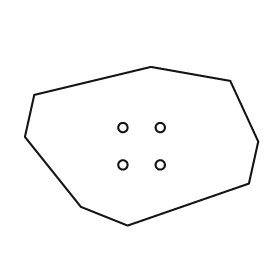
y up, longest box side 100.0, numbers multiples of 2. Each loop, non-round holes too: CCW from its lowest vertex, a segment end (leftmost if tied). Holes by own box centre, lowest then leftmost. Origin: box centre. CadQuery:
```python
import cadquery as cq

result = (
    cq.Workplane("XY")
    .moveTo(-6.0, -34.0)
    .lineTo(46.0, -16.0)
    .lineTo(50.0, 2.0)
    .lineTo(38.0, 28.0)
    .lineTo(4.0, 34.0)
    .lineTo(-46.0, 22.0)
    .lineTo(-50.0, 4.0)
    .lineTo(-26.0, -26.0)
    .close()
    .moveTo(-8.0, -8.0)
    .circle(2.0)
    .moveTo(8.0, -8.0)
    .circle(2.0)
    .moveTo(-8.0, 8.0)
    .circle(2.0)
    .moveTo(8.0, 8.0)
    .circle(2.0)
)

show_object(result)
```